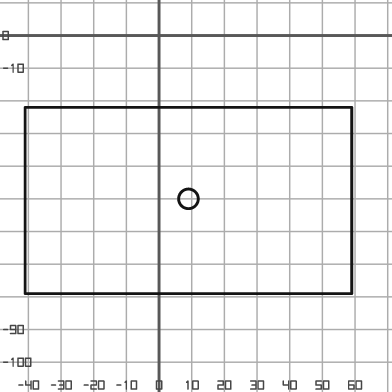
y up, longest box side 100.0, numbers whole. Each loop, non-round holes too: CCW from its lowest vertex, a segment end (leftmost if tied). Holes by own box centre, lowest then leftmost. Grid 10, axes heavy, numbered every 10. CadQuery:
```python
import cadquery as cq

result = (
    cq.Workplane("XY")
    .moveTo(-41.0, -79.0)
    .lineTo(59.0, -79.0)
    .lineTo(59.0, -22.0)
    .lineTo(-41.0, -22.0)
    .close()
    .moveTo(9.0, -50.0)
    .circle(3.0)
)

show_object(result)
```